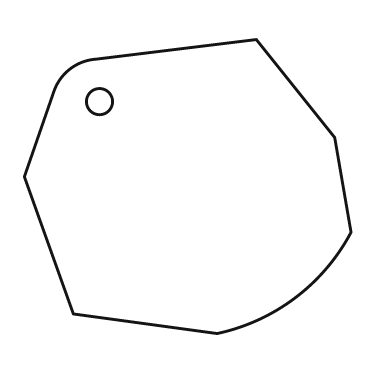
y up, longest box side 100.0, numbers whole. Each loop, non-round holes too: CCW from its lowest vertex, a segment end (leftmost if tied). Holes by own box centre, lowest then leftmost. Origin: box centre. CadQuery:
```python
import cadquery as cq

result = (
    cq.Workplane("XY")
    .moveTo(9.0, -45.0)
    .threePointArc((33.0, -34.0), (50.0, -14.0))
    .lineTo(45.0, 15.0)
    .lineTo(21.0, 45.0)
    .lineTo(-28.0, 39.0)
    .threePointArc((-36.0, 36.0), (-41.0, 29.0))
    .lineTo(-50.0, 3.0)
    .lineTo(-35.0, -39.0)
    .close()
    .moveTo(-27.0, 26.0)
    .circle(4.0)
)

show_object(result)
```